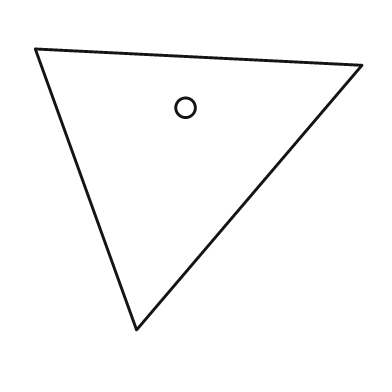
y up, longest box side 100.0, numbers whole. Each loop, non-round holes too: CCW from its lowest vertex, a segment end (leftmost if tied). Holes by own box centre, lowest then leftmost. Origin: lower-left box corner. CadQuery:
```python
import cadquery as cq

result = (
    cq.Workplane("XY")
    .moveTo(31.0, 0.0)
    .lineTo(100.0, 81.0)
    .lineTo(0.0, 86.0)
    .close()
    .moveTo(46.0, 68.0)
    .circle(3.0)
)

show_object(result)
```